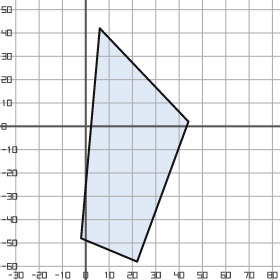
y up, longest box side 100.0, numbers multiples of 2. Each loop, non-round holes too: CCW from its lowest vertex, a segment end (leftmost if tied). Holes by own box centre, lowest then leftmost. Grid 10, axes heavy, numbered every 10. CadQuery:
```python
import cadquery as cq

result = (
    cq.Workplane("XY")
    .moveTo(22.0, -58.0)
    .lineTo(44.0, 2.0)
    .lineTo(6.0, 42.0)
    .lineTo(-2.0, -48.0)
    .close()
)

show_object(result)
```